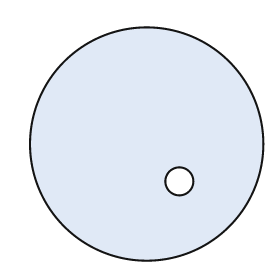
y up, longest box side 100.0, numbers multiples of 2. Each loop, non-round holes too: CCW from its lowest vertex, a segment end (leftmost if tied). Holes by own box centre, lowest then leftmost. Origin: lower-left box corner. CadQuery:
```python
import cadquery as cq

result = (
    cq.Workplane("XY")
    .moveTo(50.0, 50.0)
    .circle(50.0)
    .moveTo(64.0, 34.0)
    .circle(6.0)
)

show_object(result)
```